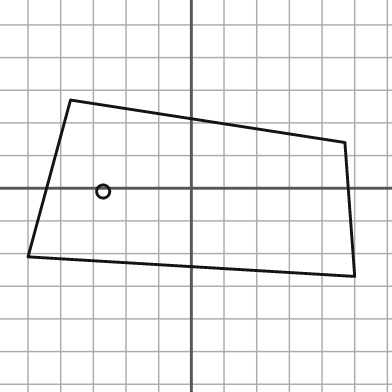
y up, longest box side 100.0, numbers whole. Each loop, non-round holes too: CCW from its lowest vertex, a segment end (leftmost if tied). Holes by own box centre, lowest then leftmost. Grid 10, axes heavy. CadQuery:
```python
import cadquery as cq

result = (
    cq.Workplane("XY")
    .moveTo(50.0, -27.0)
    .lineTo(47.0, 14.0)
    .lineTo(-37.0, 27.0)
    .lineTo(-50.0, -21.0)
    .close()
    .moveTo(-27.0, -1.0)
    .circle(2.0)
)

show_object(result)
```